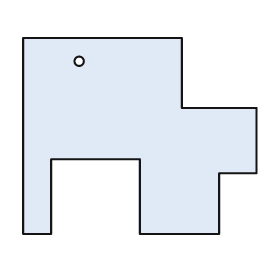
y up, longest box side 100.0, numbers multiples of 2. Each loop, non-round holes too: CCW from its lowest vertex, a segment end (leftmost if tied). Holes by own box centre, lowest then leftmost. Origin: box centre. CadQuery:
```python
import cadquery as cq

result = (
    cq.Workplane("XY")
    .moveTo(-50.0, -42.0)
    .lineTo(-38.0, -42.0)
    .lineTo(-38.0, -10.0)
    .lineTo(0.0, -10.0)
    .lineTo(0.0, -42.0)
    .lineTo(34.0, -42.0)
    .lineTo(34.0, -16.0)
    .lineTo(50.0, -16.0)
    .lineTo(50.0, 12.0)
    .lineTo(18.0, 12.0)
    .lineTo(18.0, 42.0)
    .lineTo(-50.0, 42.0)
    .close()
    .moveTo(-26.0, 32.0)
    .circle(2.0)
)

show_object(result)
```